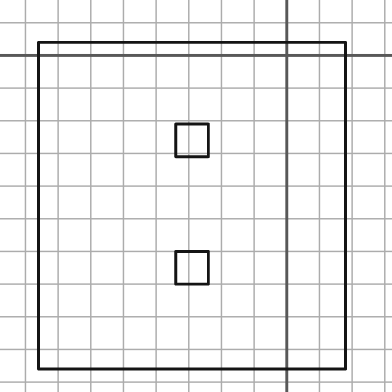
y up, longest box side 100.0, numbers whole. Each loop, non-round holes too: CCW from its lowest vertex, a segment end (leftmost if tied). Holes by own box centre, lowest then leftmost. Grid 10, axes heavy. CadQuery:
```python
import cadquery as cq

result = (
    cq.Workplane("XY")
    .moveTo(-76.0, -96.0)
    .lineTo(18.0, -96.0)
    .lineTo(18.0, 4.0)
    .lineTo(-76.0, 4.0)
    .close()
    .moveTo(-34.0, -70.0)
    .lineTo(-24.0, -70.0)
    .lineTo(-24.0, -60.0)
    .lineTo(-34.0, -60.0)
    .close()
    .moveTo(-34.0, -31.0)
    .lineTo(-24.0, -31.0)
    .lineTo(-24.0, -21.0)
    .lineTo(-34.0, -21.0)
    .close()
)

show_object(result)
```